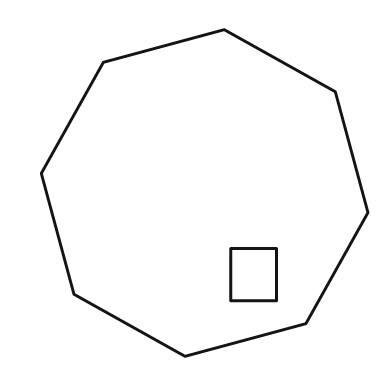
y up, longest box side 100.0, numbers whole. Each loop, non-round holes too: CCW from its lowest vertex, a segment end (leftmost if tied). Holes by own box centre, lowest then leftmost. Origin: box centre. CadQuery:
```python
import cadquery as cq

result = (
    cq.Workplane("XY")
    .moveTo(-6.0, -50.0)
    .lineTo(31.0, -40.0)
    .lineTo(50.0, -6.0)
    .lineTo(40.0, 31.0)
    .lineTo(6.0, 50.0)
    .lineTo(-31.0, 40.0)
    .lineTo(-50.0, 6.0)
    .lineTo(-40.0, -31.0)
    .close()
    .moveTo(8.0, -33.0)
    .lineTo(22.0, -33.0)
    .lineTo(22.0, -17.0)
    .lineTo(8.0, -17.0)
    .close()
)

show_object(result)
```